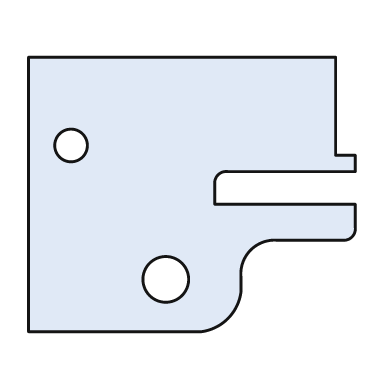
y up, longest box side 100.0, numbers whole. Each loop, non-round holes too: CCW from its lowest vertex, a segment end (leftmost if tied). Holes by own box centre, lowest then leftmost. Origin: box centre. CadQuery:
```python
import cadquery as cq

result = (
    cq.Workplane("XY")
    .moveTo(-50.0, -42.0)
    .lineTo(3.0, -42.0)
    .threePointArc((11.0, -38.0), (15.0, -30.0))
    .lineTo(15.0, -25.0)
    .threePointArc((18.0, -17.0), (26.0, -14.0))
    .lineTo(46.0, -14.0)
    .threePointArc((49.0, -13.0), (50.0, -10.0))
    .lineTo(50.0, -3.0)
    .lineTo(7.0, -3.0)
    .lineTo(7.0, 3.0)
    .threePointArc((8.0, 6.0), (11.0, 7.0))
    .lineTo(50.0, 7.0)
    .lineTo(50.0, 12.0)
    .lineTo(44.0, 12.0)
    .lineTo(44.0, 42.0)
    .lineTo(-50.0, 42.0)
    .close()
    .moveTo(-8.0, -26.0)
    .circle(7.0)
    .moveTo(-37.0, 15.0)
    .circle(5.0)
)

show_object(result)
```